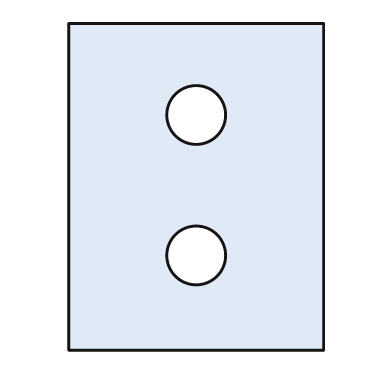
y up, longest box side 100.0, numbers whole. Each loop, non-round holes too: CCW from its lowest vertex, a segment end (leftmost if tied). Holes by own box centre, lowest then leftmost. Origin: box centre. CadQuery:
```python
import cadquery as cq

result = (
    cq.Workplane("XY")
    .moveTo(-39.0, -50.0)
    .lineTo(39.0, -50.0)
    .lineTo(39.0, 50.0)
    .lineTo(-39.0, 50.0)
    .close()
    .moveTo(0.0, -21.0)
    .circle(9.0)
    .moveTo(0.0, 22.0)
    .circle(9.0)
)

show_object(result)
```